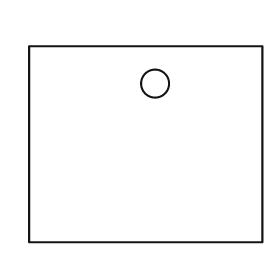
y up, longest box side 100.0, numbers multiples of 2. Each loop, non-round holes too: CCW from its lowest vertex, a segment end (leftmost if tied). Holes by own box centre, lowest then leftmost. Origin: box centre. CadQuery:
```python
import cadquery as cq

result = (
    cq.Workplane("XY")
    .moveTo(-50.0, -42.0)
    .lineTo(50.0, -42.0)
    .lineTo(50.0, 42.0)
    .lineTo(-50.0, 42.0)
    .close()
    .moveTo(4.0, 26.0)
    .circle(6.0)
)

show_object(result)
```